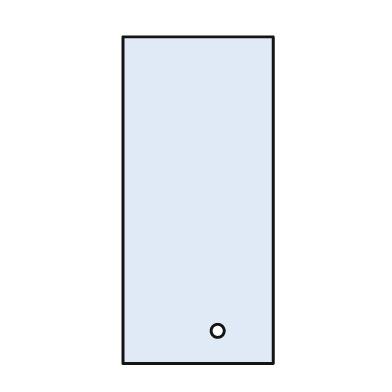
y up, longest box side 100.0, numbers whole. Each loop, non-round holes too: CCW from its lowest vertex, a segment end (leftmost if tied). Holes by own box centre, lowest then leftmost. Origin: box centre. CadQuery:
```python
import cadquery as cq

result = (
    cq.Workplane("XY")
    .moveTo(-23.0, -50.0)
    .lineTo(23.0, -50.0)
    .lineTo(23.0, 50.0)
    .lineTo(-23.0, 50.0)
    .close()
    .moveTo(6.0, -40.0)
    .circle(2.0)
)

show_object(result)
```